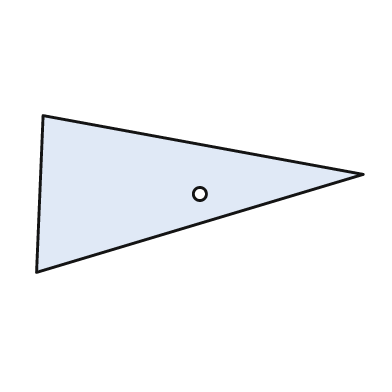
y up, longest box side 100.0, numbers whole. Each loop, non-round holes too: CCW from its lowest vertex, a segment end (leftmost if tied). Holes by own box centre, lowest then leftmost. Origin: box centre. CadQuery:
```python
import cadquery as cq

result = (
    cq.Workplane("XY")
    .moveTo(-50.0, -24.0)
    .lineTo(50.0, 6.0)
    .lineTo(-48.0, 24.0)
    .close()
    .moveTo(0.0, 0.0)
    .circle(2.0)
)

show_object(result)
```